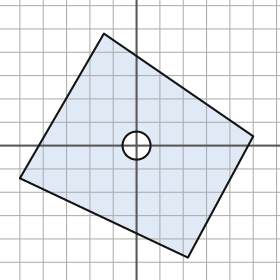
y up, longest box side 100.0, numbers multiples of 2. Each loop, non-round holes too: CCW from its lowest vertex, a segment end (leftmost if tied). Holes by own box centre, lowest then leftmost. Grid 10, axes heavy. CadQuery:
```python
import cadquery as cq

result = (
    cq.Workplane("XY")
    .moveTo(22.0, -48.0)
    .lineTo(50.0, 4.0)
    .lineTo(-14.0, 48.0)
    .lineTo(-50.0, -14.0)
    .close()
    .moveTo(0.0, 0.0)
    .circle(6.0)
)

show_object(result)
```